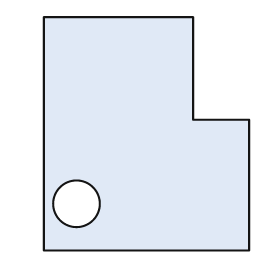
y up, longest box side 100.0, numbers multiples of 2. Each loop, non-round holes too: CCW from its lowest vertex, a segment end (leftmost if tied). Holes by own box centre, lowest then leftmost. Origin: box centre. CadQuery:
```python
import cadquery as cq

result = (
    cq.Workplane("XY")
    .moveTo(-44.0, -50.0)
    .lineTo(44.0, -50.0)
    .lineTo(44.0, 6.0)
    .lineTo(20.0, 6.0)
    .lineTo(20.0, 50.0)
    .lineTo(-44.0, 50.0)
    .close()
    .moveTo(-30.0, -30.0)
    .circle(10.0)
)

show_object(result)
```